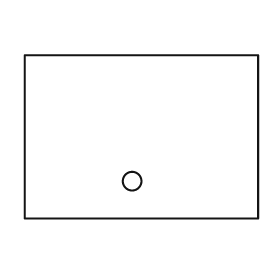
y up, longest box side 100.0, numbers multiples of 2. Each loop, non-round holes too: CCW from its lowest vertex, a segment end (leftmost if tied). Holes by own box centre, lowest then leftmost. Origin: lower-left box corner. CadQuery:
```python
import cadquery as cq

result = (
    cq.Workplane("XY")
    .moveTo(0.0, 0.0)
    .lineTo(100.0, 0.0)
    .lineTo(100.0, 70.0)
    .lineTo(0.0, 70.0)
    .close()
    .moveTo(46.0, 16.0)
    .circle(4.0)
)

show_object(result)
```